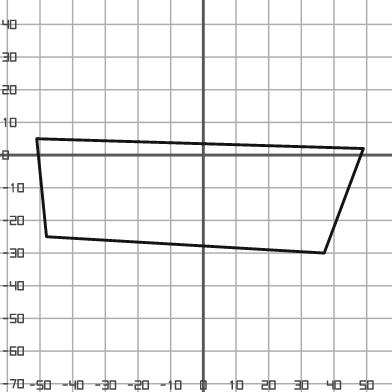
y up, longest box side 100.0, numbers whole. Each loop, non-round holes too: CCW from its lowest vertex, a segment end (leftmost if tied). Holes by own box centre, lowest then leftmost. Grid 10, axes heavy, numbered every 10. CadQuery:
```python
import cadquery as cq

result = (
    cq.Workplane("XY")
    .moveTo(37.0, -30.0)
    .lineTo(49.0, 2.0)
    .lineTo(-51.0, 5.0)
    .lineTo(-48.0, -25.0)
    .close()
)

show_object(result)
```